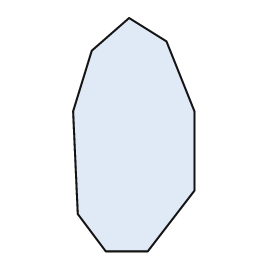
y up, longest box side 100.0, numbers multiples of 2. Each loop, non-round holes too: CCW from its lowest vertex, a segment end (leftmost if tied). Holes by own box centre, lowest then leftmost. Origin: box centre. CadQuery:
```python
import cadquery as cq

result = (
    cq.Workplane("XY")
    .moveTo(-12.0, -50.0)
    .lineTo(6.0, -50.0)
    .lineTo(26.0, -24.0)
    .lineTo(26.0, 10.0)
    .lineTo(14.0, 40.0)
    .lineTo(-2.0, 50.0)
    .lineTo(-18.0, 36.0)
    .lineTo(-26.0, 10.0)
    .lineTo(-24.0, -34.0)
    .close()
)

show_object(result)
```